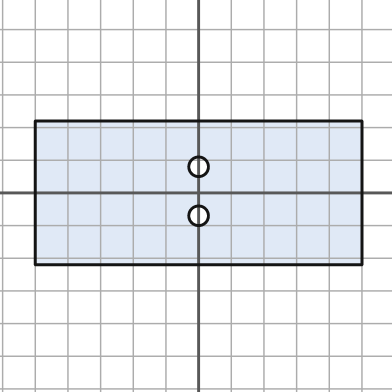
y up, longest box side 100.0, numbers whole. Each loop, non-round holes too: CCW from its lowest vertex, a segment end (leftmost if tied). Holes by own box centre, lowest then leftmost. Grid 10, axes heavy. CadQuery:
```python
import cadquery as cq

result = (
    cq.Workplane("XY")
    .moveTo(-50.0, -22.0)
    .lineTo(50.0, -22.0)
    .lineTo(50.0, 22.0)
    .lineTo(-50.0, 22.0)
    .close()
    .moveTo(0.0, -7.0)
    .circle(3.0)
    .moveTo(0.0, 8.0)
    .circle(3.0)
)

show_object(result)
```